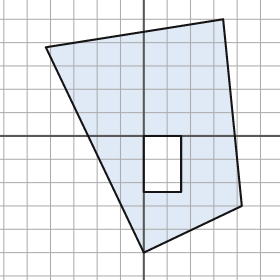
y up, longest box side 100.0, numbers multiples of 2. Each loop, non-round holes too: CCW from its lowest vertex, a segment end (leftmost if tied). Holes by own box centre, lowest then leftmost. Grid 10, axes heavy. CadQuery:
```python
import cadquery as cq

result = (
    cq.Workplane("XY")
    .moveTo(0.0, -50.0)
    .lineTo(42.0, -30.0)
    .lineTo(34.0, 50.0)
    .lineTo(-42.0, 38.0)
    .close()
    .moveTo(0.0, -24.0)
    .lineTo(16.0, -24.0)
    .lineTo(16.0, 0.0)
    .lineTo(0.0, 0.0)
    .close()
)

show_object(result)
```